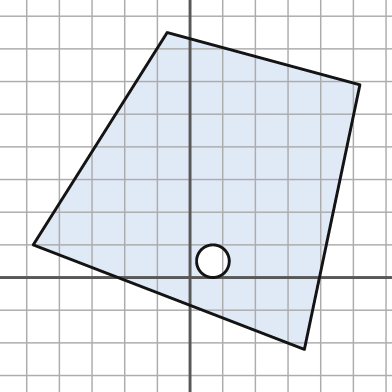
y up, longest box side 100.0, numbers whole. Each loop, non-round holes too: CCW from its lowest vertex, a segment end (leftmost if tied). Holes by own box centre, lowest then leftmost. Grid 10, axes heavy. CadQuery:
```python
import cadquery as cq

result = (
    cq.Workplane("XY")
    .moveTo(35.0, -22.0)
    .lineTo(52.0, 59.0)
    .lineTo(-7.0, 75.0)
    .lineTo(-48.0, 10.0)
    .close()
    .moveTo(7.0, 5.0)
    .circle(5.0)
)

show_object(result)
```